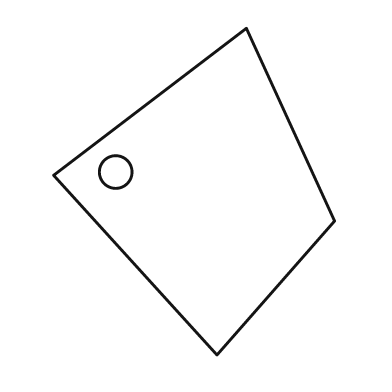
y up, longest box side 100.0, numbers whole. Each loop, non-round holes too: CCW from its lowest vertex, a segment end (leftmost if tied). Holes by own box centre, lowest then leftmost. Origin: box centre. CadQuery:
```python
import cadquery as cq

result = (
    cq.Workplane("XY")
    .moveTo(7.0, -50.0)
    .lineTo(43.0, -9.0)
    .lineTo(16.0, 50.0)
    .lineTo(-43.0, 5.0)
    .close()
    .moveTo(-24.0, 6.0)
    .circle(5.0)
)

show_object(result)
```